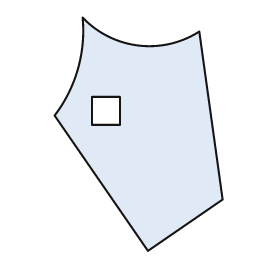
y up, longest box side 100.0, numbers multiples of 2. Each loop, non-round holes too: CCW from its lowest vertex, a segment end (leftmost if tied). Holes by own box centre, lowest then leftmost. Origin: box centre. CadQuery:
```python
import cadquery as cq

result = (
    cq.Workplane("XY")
    .moveTo(4.0, -50.0)
    .lineTo(36.0, -28.0)
    .lineTo(26.0, 44.0)
    .threePointArc((0.0, 38.0), (-24.0, 50.0))
    .threePointArc((-26.0, 28.0), (-36.0, 8.0))
    .close()
    .moveTo(-20.0, 4.0)
    .lineTo(-8.0, 4.0)
    .lineTo(-8.0, 16.0)
    .lineTo(-20.0, 16.0)
    .close()
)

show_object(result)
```